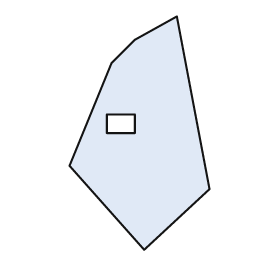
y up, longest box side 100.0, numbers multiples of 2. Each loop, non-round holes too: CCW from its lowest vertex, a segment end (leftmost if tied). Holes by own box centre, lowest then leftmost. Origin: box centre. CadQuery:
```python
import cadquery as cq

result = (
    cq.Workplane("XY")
    .moveTo(2.0, -50.0)
    .lineTo(30.0, -24.0)
    .lineTo(16.0, 50.0)
    .lineTo(-2.0, 40.0)
    .lineTo(-12.0, 30.0)
    .lineTo(-30.0, -14.0)
    .close()
    .moveTo(-14.0, 0.0)
    .lineTo(-2.0, 0.0)
    .lineTo(-2.0, 8.0)
    .lineTo(-14.0, 8.0)
    .close()
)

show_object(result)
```